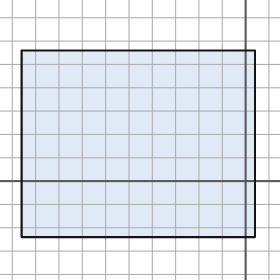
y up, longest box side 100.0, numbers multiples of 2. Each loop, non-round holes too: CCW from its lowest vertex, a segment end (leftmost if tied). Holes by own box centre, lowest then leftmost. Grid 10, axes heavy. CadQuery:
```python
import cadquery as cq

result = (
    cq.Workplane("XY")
    .moveTo(-96.0, -24.0)
    .lineTo(4.0, -24.0)
    .lineTo(4.0, 56.0)
    .lineTo(-96.0, 56.0)
    .close()
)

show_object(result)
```